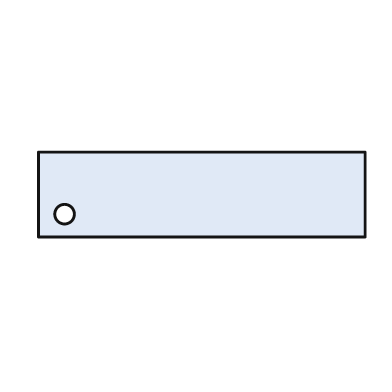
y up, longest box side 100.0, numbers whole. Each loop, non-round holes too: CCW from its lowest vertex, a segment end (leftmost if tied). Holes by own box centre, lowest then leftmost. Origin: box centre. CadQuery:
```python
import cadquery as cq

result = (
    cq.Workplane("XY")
    .moveTo(-50.0, -13.0)
    .lineTo(50.0, -13.0)
    .lineTo(50.0, 13.0)
    .lineTo(-50.0, 13.0)
    .close()
    .moveTo(-42.0, -6.0)
    .circle(3.0)
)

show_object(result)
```